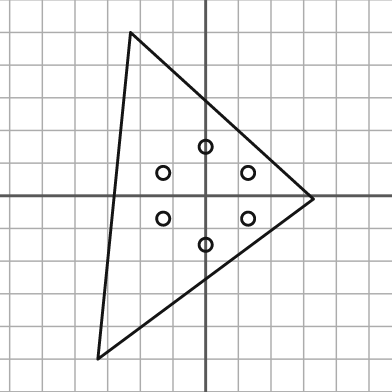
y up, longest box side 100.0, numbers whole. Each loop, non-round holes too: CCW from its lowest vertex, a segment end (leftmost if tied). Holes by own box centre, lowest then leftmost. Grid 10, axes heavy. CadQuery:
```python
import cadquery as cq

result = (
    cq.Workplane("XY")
    .moveTo(-33.0, -50.0)
    .lineTo(33.0, -1.0)
    .lineTo(-23.0, 50.0)
    .close()
    .moveTo(0.0, -15.0)
    .circle(2.0)
    .moveTo(-13.0, -7.0)
    .circle(2.0)
    .moveTo(13.0, -7.0)
    .circle(2.0)
    .moveTo(-13.0, 7.0)
    .circle(2.0)
    .moveTo(13.0, 7.0)
    .circle(2.0)
    .moveTo(0.0, 15.0)
    .circle(2.0)
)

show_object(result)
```